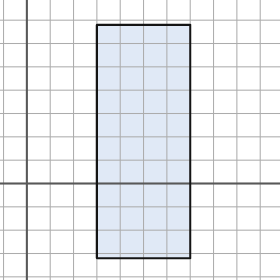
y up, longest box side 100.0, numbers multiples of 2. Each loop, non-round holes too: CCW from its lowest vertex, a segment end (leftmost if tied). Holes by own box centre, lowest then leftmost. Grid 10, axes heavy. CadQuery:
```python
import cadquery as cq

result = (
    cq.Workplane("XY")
    .moveTo(30.0, -32.0)
    .lineTo(70.0, -32.0)
    .lineTo(70.0, 68.0)
    .lineTo(30.0, 68.0)
    .close()
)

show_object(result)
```